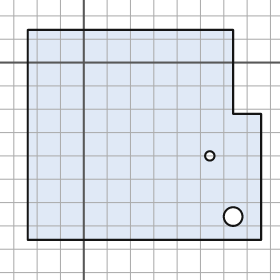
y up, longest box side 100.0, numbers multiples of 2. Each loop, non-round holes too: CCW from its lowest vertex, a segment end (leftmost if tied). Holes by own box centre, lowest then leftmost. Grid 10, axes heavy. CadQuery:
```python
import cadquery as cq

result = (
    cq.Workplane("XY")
    .moveTo(-24.0, -76.0)
    .lineTo(76.0, -76.0)
    .lineTo(76.0, -22.0)
    .lineTo(64.0, -22.0)
    .lineTo(64.0, 14.0)
    .lineTo(-24.0, 14.0)
    .close()
    .moveTo(64.0, -66.0)
    .circle(4.0)
    .moveTo(54.0, -40.0)
    .circle(2.0)
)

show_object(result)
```